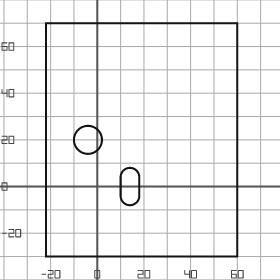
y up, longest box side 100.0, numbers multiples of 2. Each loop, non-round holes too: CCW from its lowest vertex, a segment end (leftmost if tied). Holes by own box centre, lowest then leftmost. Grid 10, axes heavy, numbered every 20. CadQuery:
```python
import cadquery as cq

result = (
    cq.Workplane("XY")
    .moveTo(-22.0, -30.0)
    .lineTo(60.0, -30.0)
    .lineTo(60.0, 70.0)
    .lineTo(-22.0, 70.0)
    .close()
    .moveTo(10.0, -4.0)
    .threePointArc((14.0, -8.0), (18.0, -4.0))
    .lineTo(18.0, 4.0)
    .threePointArc((14.0, 8.0), (10.0, 4.0))
    .close()
    .moveTo(-4.0, 20.0)
    .circle(6.0)
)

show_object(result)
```